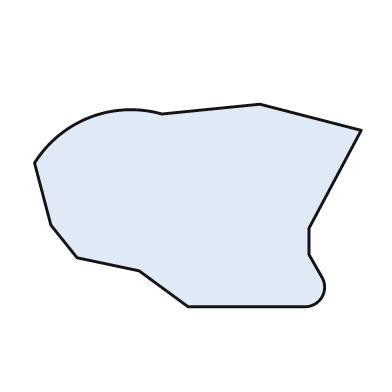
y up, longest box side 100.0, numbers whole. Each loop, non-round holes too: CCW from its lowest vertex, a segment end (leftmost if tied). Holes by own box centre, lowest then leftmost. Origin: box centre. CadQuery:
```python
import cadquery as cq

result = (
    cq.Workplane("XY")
    .moveTo(-3.0, -31.0)
    .lineTo(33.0, -31.0)
    .threePointArc((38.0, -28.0), (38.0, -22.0))
    .lineTo(34.0, -15.0)
    .lineTo(34.0, -7.0)
    .lineTo(50.0, 23.0)
    .lineTo(19.0, 31.0)
    .lineTo(-11.0, 28.0)
    .threePointArc((-33.0, 27.0), (-50.0, 13.0))
    .lineTo(-45.0, -6.0)
    .lineTo(-37.0, -16.0)
    .lineTo(-18.0, -20.0)
    .close()
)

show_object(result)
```